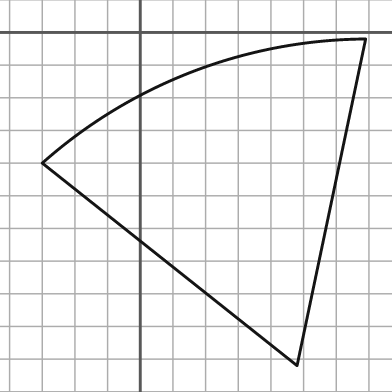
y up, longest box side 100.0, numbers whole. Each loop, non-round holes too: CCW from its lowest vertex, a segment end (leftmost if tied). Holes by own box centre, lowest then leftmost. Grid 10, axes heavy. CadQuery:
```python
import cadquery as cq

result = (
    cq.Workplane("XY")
    .moveTo(48.0, -102.0)
    .lineTo(69.0, -2.0)
    .threePointArc((16.0, -12.0), (-30.0, -40.0))
    .close()
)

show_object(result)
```